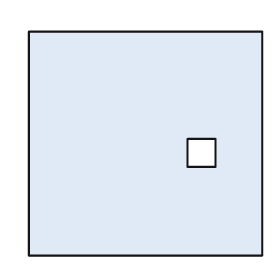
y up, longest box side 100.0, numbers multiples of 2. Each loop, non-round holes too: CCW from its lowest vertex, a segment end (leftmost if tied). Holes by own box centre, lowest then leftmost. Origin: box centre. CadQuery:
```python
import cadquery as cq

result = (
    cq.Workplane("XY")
    .moveTo(-50.0, -48.0)
    .lineTo(50.0, -48.0)
    .lineTo(50.0, 48.0)
    .lineTo(-50.0, 48.0)
    .close()
    .moveTo(18.0, -10.0)
    .lineTo(30.0, -10.0)
    .lineTo(30.0, 2.0)
    .lineTo(18.0, 2.0)
    .close()
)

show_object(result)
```